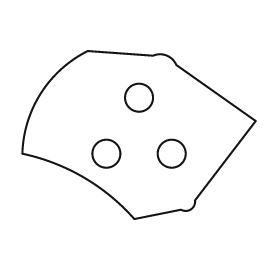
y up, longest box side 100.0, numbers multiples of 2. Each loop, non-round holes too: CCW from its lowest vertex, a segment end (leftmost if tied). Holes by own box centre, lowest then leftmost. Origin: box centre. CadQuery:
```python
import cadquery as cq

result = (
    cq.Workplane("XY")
    .moveTo(-2.0, -36.0)
    .lineTo(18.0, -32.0)
    .threePointArc((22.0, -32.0), (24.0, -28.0))
    .lineTo(50.0, 6.0)
    .lineTo(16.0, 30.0)
    .threePointArc((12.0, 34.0), (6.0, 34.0))
    .lineTo(-22.0, 36.0)
    .threePointArc((-42.0, 18.0), (-50.0, -8.0))
    .threePointArc((-24.0, -18.0), (-2.0, -36.0))
    .close()
    .moveTo(-14.0, -8.0)
    .circle(6.0)
    .moveTo(14.0, -8.0)
    .circle(6.0)
    .moveTo(0.0, 16.0)
    .circle(6.0)
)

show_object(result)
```